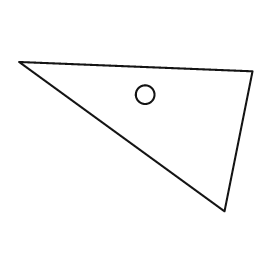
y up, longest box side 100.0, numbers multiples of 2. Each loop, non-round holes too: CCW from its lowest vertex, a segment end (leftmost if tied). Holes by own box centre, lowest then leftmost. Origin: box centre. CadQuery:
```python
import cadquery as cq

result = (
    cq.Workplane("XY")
    .moveTo(38.0, -32.0)
    .lineTo(50.0, 28.0)
    .lineTo(-50.0, 32.0)
    .close()
    .moveTo(4.0, 18.0)
    .circle(4.0)
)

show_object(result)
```